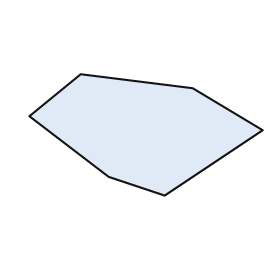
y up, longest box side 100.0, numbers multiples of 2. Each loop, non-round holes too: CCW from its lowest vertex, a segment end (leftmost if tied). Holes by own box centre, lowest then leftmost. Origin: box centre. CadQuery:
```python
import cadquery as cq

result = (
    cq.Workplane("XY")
    .moveTo(8.0, -26.0)
    .lineTo(50.0, 2.0)
    .lineTo(20.0, 20.0)
    .lineTo(-28.0, 26.0)
    .lineTo(-50.0, 8.0)
    .lineTo(-16.0, -18.0)
    .close()
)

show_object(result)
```